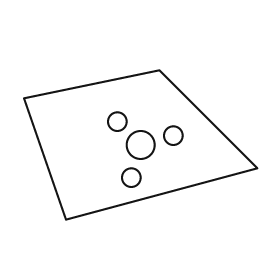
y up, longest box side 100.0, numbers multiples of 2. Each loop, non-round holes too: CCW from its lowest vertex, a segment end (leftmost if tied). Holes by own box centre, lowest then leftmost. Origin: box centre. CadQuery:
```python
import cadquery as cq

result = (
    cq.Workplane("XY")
    .moveTo(-32.0, -32.0)
    .lineTo(50.0, -10.0)
    .lineTo(8.0, 32.0)
    .lineTo(-50.0, 20.0)
    .close()
    .moveTo(-4.0, -14.0)
    .circle(4.0)
    .moveTo(0.0, 0.0)
    .circle(6.0)
    .moveTo(14.0, 4.0)
    .circle(4.0)
    .moveTo(-10.0, 10.0)
    .circle(4.0)
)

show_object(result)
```